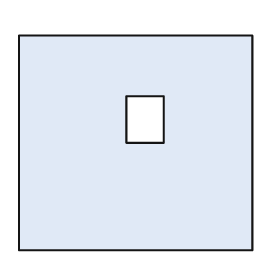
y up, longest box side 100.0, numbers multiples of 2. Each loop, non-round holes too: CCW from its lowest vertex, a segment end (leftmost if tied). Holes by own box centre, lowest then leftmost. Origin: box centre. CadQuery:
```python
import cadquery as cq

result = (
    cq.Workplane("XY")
    .moveTo(-50.0, -46.0)
    .lineTo(50.0, -46.0)
    .lineTo(50.0, 46.0)
    .lineTo(-50.0, 46.0)
    .close()
    .moveTo(-4.0, 0.0)
    .lineTo(12.0, 0.0)
    .lineTo(12.0, 20.0)
    .lineTo(-4.0, 20.0)
    .close()
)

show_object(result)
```